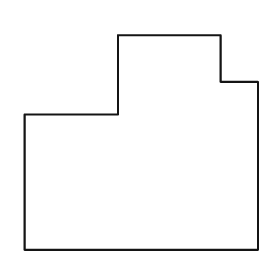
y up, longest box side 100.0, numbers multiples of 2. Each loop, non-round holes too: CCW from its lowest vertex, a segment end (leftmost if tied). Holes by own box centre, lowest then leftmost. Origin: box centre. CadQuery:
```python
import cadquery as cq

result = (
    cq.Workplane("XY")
    .moveTo(-50.0, -46.0)
    .lineTo(50.0, -46.0)
    .lineTo(50.0, 26.0)
    .lineTo(34.0, 26.0)
    .lineTo(34.0, 46.0)
    .lineTo(-10.0, 46.0)
    .lineTo(-10.0, 12.0)
    .lineTo(-50.0, 12.0)
    .close()
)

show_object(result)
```